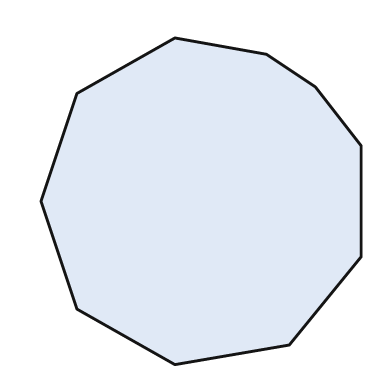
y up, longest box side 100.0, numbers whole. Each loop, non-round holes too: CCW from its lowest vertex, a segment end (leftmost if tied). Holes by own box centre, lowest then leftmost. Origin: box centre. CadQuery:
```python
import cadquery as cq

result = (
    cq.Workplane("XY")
    .moveTo(-8.0, -50.0)
    .lineTo(27.0, -44.0)
    .lineTo(49.0, -17.0)
    .lineTo(49.0, 17.0)
    .lineTo(35.0, 35.0)
    .lineTo(20.0, 45.0)
    .lineTo(-8.0, 50.0)
    .lineTo(-38.0, 33.0)
    .lineTo(-49.0, 0.0)
    .lineTo(-38.0, -33.0)
    .close()
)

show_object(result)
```